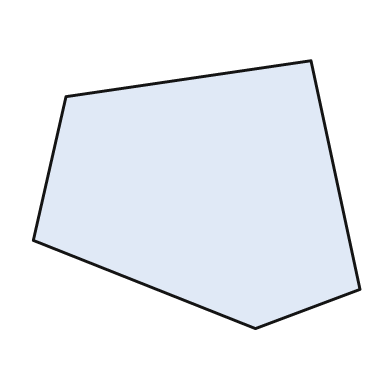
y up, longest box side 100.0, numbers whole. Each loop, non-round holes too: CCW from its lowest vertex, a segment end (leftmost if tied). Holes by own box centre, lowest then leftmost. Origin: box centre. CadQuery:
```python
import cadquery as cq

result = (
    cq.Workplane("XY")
    .moveTo(18.0, -41.0)
    .lineTo(50.0, -29.0)
    .lineTo(35.0, 41.0)
    .lineTo(-40.0, 30.0)
    .lineTo(-50.0, -14.0)
    .close()
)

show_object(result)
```